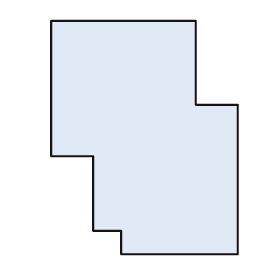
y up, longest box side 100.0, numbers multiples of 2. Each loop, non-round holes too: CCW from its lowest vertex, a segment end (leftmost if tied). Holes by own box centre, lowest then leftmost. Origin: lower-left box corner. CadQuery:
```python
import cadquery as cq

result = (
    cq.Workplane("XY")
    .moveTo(30.0, 0.0)
    .lineTo(80.0, 0.0)
    .lineTo(80.0, 64.0)
    .lineTo(62.0, 64.0)
    .lineTo(62.0, 100.0)
    .lineTo(0.0, 100.0)
    .lineTo(0.0, 42.0)
    .lineTo(18.0, 42.0)
    .lineTo(18.0, 10.0)
    .lineTo(30.0, 10.0)
    .close()
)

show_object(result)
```